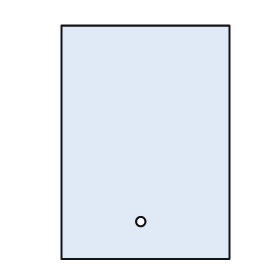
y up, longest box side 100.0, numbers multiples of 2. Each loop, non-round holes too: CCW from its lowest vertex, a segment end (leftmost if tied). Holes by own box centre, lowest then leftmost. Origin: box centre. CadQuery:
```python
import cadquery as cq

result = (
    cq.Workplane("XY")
    .moveTo(-36.0, -50.0)
    .lineTo(36.0, -50.0)
    .lineTo(36.0, 50.0)
    .lineTo(-36.0, 50.0)
    .close()
    .moveTo(-2.0, -34.0)
    .circle(2.0)
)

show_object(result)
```